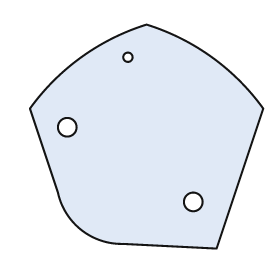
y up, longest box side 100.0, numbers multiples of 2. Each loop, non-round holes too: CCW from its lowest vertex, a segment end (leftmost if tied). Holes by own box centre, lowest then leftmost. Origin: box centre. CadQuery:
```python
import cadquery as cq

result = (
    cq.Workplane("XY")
    .moveTo(30.0, -48.0)
    .lineTo(50.0, 12.0)
    .threePointArc((28.0, 34.0), (0.0, 48.0))
    .threePointArc((-28.0, 34.0), (-50.0, 12.0))
    .lineTo(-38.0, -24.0)
    .threePointArc((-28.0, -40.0), (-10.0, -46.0))
    .close()
    .moveTo(20.0, -28.0)
    .circle(4.0)
    .moveTo(-34.0, 4.0)
    .circle(4.0)
    .moveTo(-8.0, 34.0)
    .circle(2.0)
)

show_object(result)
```